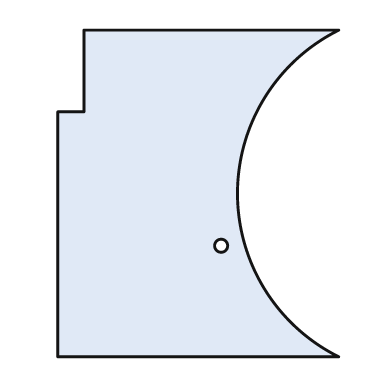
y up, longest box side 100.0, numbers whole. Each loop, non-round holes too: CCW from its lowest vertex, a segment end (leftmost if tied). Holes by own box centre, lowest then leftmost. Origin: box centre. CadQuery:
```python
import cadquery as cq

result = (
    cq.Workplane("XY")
    .moveTo(-43.0, -50.0)
    .lineTo(43.0, -50.0)
    .threePointArc((12.0, 0.0), (43.0, 50.0))
    .lineTo(-35.0, 50.0)
    .lineTo(-35.0, 25.0)
    .lineTo(-43.0, 25.0)
    .close()
    .moveTo(7.0, -16.0)
    .circle(2.0)
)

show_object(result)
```